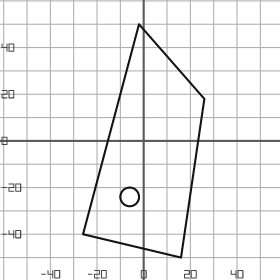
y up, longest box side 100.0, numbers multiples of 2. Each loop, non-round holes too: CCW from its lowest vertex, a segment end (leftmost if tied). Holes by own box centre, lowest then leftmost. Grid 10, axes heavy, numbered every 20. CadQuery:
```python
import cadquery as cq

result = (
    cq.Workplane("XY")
    .moveTo(16.0, -50.0)
    .lineTo(26.0, 18.0)
    .lineTo(-2.0, 50.0)
    .lineTo(-26.0, -40.0)
    .close()
    .moveTo(-6.0, -24.0)
    .circle(4.0)
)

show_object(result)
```